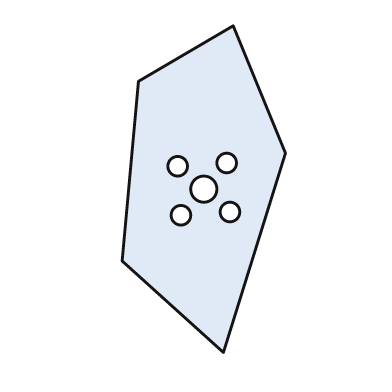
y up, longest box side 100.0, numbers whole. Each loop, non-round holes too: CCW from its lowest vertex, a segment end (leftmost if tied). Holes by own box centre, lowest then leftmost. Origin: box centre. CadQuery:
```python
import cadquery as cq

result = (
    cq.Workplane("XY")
    .moveTo(6.0, -50.0)
    .lineTo(25.0, 11.0)
    .lineTo(9.0, 50.0)
    .lineTo(-20.0, 33.0)
    .lineTo(-25.0, -22.0)
    .close()
    .moveTo(-7.0, -8.0)
    .circle(3.0)
    .moveTo(8.0, -7.0)
    .circle(3.0)
    .moveTo(0.0, 0.0)
    .circle(4.0)
    .moveTo(-8.0, 7.0)
    .circle(3.0)
    .moveTo(7.0, 8.0)
    .circle(3.0)
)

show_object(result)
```